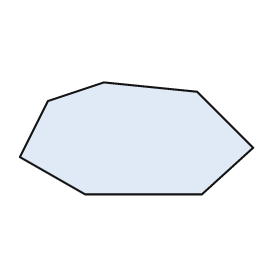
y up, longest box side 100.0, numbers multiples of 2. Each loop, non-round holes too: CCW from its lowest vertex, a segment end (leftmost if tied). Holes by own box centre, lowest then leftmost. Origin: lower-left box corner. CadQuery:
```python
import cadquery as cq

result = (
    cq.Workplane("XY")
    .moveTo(28.0, 0.0)
    .lineTo(78.0, 0.0)
    .lineTo(100.0, 20.0)
    .lineTo(76.0, 44.0)
    .lineTo(36.0, 48.0)
    .lineTo(12.0, 40.0)
    .lineTo(0.0, 16.0)
    .close()
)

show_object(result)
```